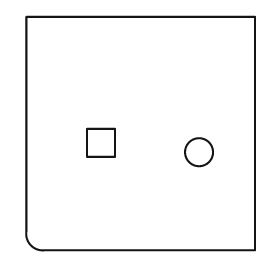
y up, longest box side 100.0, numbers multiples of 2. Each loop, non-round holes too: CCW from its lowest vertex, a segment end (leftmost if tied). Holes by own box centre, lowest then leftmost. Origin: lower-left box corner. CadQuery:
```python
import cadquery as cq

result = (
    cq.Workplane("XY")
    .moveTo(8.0, 0.0)
    .lineTo(98.0, 0.0)
    .lineTo(98.0, 100.0)
    .lineTo(0.0, 100.0)
    .lineTo(0.0, 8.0)
    .threePointArc((2.0, 2.0), (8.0, 0.0))
    .close()
    .moveTo(74.0, 42.0)
    .circle(6.0)
    .moveTo(26.0, 40.0)
    .lineTo(38.0, 40.0)
    .lineTo(38.0, 52.0)
    .lineTo(26.0, 52.0)
    .close()
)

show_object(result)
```